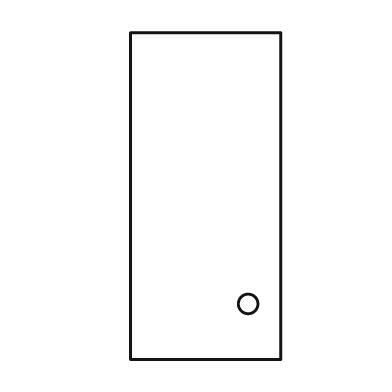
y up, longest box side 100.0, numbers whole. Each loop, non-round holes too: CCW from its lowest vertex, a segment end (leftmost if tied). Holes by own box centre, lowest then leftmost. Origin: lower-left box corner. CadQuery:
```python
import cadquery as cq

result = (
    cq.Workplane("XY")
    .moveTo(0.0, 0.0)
    .lineTo(46.0, 0.0)
    .lineTo(46.0, 100.0)
    .lineTo(0.0, 100.0)
    .close()
    .moveTo(36.0, 17.0)
    .circle(3.0)
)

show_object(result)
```